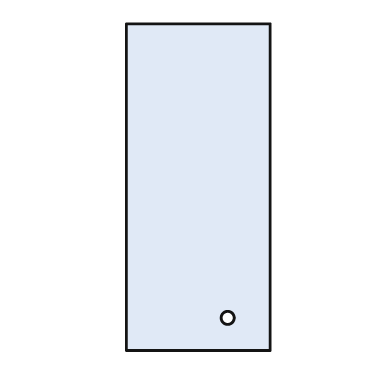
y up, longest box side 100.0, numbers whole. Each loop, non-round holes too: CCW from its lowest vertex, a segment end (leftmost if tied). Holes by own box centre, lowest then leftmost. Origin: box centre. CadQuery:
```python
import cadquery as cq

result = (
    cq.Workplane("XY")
    .moveTo(-22.0, -50.0)
    .lineTo(22.0, -50.0)
    .lineTo(22.0, 50.0)
    .lineTo(-22.0, 50.0)
    .close()
    .moveTo(9.0, -40.0)
    .circle(2.0)
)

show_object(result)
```